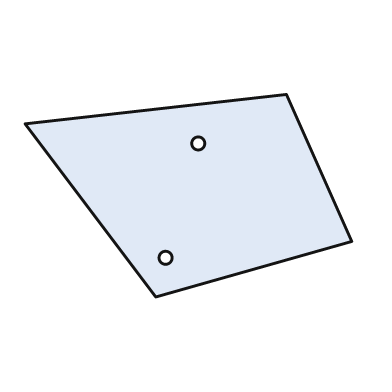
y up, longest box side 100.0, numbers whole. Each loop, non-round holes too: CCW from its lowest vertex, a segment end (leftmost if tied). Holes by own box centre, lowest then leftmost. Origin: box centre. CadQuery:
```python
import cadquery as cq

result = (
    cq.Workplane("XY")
    .moveTo(-10.0, -31.0)
    .lineTo(50.0, -14.0)
    .lineTo(30.0, 31.0)
    .lineTo(-50.0, 22.0)
    .close()
    .moveTo(-7.0, -19.0)
    .circle(2.0)
    .moveTo(3.0, 16.0)
    .circle(2.0)
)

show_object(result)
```